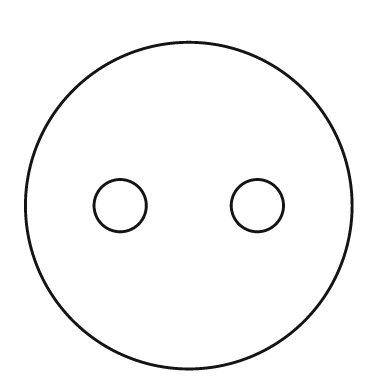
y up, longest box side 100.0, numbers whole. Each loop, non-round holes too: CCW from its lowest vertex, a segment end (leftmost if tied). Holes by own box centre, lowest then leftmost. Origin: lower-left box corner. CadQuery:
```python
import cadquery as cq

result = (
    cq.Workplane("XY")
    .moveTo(50.0, 50.0)
    .circle(50.0)
    .moveTo(29.0, 50.0)
    .circle(8.0)
    .moveTo(71.0, 50.0)
    .circle(8.0)
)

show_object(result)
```